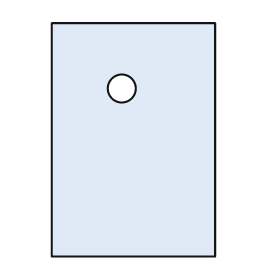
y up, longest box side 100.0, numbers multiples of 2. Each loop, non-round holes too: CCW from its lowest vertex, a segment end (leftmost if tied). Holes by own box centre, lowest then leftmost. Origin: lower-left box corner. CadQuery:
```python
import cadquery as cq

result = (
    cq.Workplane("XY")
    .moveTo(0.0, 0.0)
    .lineTo(70.0, 0.0)
    .lineTo(70.0, 100.0)
    .lineTo(0.0, 100.0)
    .close()
    .moveTo(30.0, 72.0)
    .circle(6.0)
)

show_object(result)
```